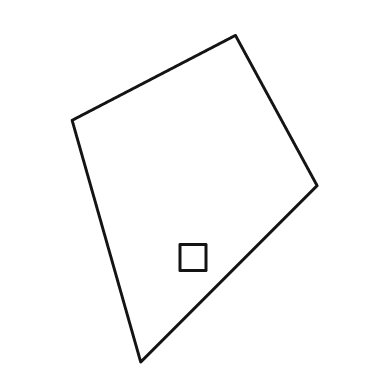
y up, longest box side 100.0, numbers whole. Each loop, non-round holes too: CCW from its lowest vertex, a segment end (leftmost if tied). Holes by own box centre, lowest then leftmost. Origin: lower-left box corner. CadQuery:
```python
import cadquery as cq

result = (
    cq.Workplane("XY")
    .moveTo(21.0, 0.0)
    .lineTo(75.0, 54.0)
    .lineTo(50.0, 100.0)
    .lineTo(0.0, 74.0)
    .close()
    .moveTo(33.0, 28.0)
    .lineTo(41.0, 28.0)
    .lineTo(41.0, 36.0)
    .lineTo(33.0, 36.0)
    .close()
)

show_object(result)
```